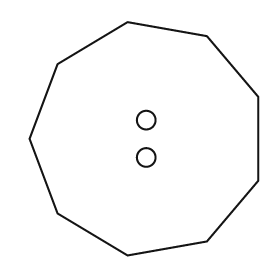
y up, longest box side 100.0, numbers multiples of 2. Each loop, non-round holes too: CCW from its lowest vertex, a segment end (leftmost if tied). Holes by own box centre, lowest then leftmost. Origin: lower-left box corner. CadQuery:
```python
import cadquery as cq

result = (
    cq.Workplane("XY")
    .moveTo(42.0, 0.0)
    .lineTo(76.0, 6.0)
    .lineTo(98.0, 32.0)
    .lineTo(98.0, 68.0)
    .lineTo(76.0, 94.0)
    .lineTo(42.0, 100.0)
    .lineTo(12.0, 82.0)
    .lineTo(0.0, 50.0)
    .lineTo(12.0, 18.0)
    .close()
    .moveTo(50.0, 42.0)
    .circle(4.0)
    .moveTo(50.0, 58.0)
    .circle(4.0)
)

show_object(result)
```